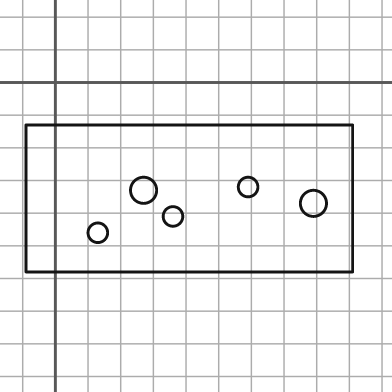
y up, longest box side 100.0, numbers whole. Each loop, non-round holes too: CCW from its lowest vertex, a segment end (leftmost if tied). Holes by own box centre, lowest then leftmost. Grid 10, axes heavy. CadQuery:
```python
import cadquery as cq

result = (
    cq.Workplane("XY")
    .moveTo(-9.0, -58.0)
    .lineTo(91.0, -58.0)
    .lineTo(91.0, -13.0)
    .lineTo(-9.0, -13.0)
    .close()
    .moveTo(13.0, -46.0)
    .circle(3.0)
    .moveTo(36.0, -41.0)
    .circle(3.0)
    .moveTo(79.0, -37.0)
    .circle(4.0)
    .moveTo(27.0, -33.0)
    .circle(4.0)
    .moveTo(59.0, -32.0)
    .circle(3.0)
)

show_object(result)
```